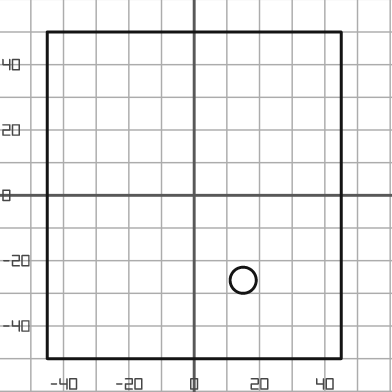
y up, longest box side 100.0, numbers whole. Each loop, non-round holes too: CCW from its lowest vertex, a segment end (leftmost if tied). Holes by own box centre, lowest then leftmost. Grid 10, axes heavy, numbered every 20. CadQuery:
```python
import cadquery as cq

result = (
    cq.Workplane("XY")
    .moveTo(-45.0, -50.0)
    .lineTo(45.0, -50.0)
    .lineTo(45.0, 50.0)
    .lineTo(-45.0, 50.0)
    .close()
    .moveTo(15.0, -26.0)
    .circle(4.0)
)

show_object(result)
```